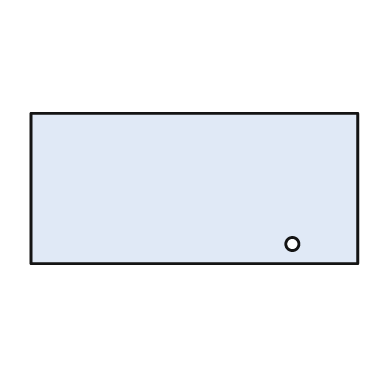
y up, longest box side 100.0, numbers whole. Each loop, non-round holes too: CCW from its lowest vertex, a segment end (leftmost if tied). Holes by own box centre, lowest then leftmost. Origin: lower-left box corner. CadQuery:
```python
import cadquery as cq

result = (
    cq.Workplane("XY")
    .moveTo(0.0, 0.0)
    .lineTo(100.0, 0.0)
    .lineTo(100.0, 46.0)
    .lineTo(0.0, 46.0)
    .close()
    .moveTo(80.0, 6.0)
    .circle(2.0)
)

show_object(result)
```